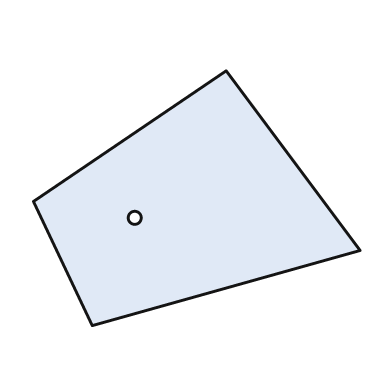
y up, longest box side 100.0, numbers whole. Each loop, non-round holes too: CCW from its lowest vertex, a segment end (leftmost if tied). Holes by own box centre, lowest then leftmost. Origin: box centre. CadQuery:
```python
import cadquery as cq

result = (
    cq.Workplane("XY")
    .moveTo(-32.0, -39.0)
    .lineTo(50.0, -16.0)
    .lineTo(9.0, 39.0)
    .lineTo(-50.0, -1.0)
    .close()
    .moveTo(-19.0, -6.0)
    .circle(2.0)
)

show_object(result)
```